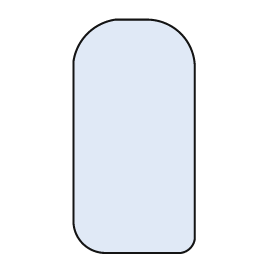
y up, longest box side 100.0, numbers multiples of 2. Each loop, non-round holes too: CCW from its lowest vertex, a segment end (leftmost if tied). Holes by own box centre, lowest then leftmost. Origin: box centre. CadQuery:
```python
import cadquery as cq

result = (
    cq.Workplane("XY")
    .moveTo(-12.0, -50.0)
    .lineTo(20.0, -50.0)
    .threePointArc((24.0, -48.0), (26.0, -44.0))
    .lineTo(26.0, 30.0)
    .threePointArc((20.0, 44.0), (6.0, 50.0))
    .lineTo(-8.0, 50.0)
    .threePointArc((-20.0, 44.0), (-26.0, 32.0))
    .lineTo(-26.0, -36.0)
    .threePointArc((-22.0, -46.0), (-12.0, -50.0))
    .close()
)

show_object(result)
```